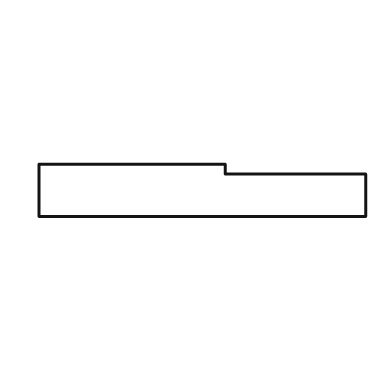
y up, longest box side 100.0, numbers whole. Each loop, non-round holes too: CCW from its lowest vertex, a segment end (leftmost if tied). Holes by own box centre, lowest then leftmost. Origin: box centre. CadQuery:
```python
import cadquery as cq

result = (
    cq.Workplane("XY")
    .moveTo(-50.0, -8.0)
    .lineTo(50.0, -8.0)
    .lineTo(50.0, 5.0)
    .lineTo(7.0, 5.0)
    .lineTo(7.0, 8.0)
    .lineTo(-50.0, 8.0)
    .close()
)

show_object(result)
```